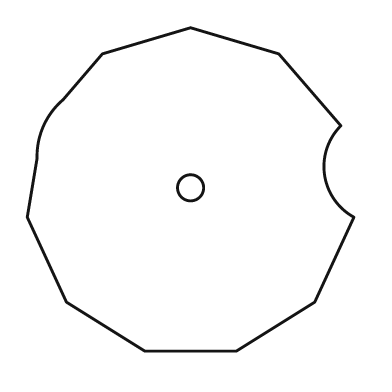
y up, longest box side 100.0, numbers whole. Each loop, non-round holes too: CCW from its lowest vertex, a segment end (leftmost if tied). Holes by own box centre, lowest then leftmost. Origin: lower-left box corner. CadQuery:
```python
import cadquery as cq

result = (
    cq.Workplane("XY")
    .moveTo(36.0, 0.0)
    .lineTo(64.0, 0.0)
    .lineTo(88.0, 15.0)
    .lineTo(100.0, 41.0)
    .threePointArc((91.0, 54.0), (96.0, 69.0))
    .lineTo(77.0, 91.0)
    .lineTo(50.0, 99.0)
    .lineTo(23.0, 91.0)
    .lineTo(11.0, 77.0)
    .threePointArc((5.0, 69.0), (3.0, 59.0))
    .lineTo(0.0, 41.0)
    .lineTo(12.0, 15.0)
    .close()
    .moveTo(50.0, 50.0)
    .circle(4.0)
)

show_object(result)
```